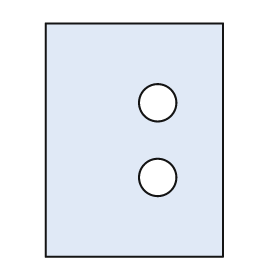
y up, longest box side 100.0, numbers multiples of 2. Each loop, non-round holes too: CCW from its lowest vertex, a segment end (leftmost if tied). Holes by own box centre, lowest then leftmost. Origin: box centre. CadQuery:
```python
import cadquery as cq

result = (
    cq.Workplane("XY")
    .moveTo(-38.0, -50.0)
    .lineTo(38.0, -50.0)
    .lineTo(38.0, 50.0)
    .lineTo(-38.0, 50.0)
    .close()
    .moveTo(10.0, -16.0)
    .circle(8.0)
    .moveTo(10.0, 16.0)
    .circle(8.0)
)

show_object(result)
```